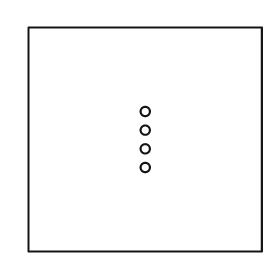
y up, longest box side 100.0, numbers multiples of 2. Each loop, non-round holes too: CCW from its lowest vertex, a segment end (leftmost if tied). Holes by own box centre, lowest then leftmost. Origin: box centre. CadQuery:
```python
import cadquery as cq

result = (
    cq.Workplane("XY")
    .moveTo(-50.0, -48.0)
    .lineTo(50.0, -48.0)
    .lineTo(50.0, 48.0)
    .lineTo(-50.0, 48.0)
    .close()
    .moveTo(0.0, -12.0)
    .circle(2.0)
    .moveTo(0.0, -4.0)
    .circle(2.0)
    .moveTo(0.0, 4.0)
    .circle(2.0)
    .moveTo(0.0, 12.0)
    .circle(2.0)
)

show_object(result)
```